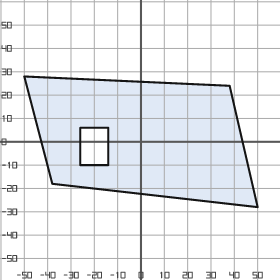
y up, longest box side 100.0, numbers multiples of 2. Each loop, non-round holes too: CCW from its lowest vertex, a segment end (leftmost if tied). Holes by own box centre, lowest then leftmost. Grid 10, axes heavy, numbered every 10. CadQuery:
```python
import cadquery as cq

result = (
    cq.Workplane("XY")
    .moveTo(50.0, -28.0)
    .lineTo(38.0, 24.0)
    .lineTo(-50.0, 28.0)
    .lineTo(-38.0, -18.0)
    .close()
    .moveTo(-26.0, -10.0)
    .lineTo(-14.0, -10.0)
    .lineTo(-14.0, 6.0)
    .lineTo(-26.0, 6.0)
    .close()
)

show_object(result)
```